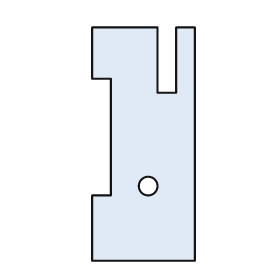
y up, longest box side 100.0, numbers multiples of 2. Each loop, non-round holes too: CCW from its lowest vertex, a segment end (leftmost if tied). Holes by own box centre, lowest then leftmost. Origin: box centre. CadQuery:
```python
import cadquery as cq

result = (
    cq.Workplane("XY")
    .moveTo(-22.0, -50.0)
    .lineTo(22.0, -50.0)
    .lineTo(22.0, 50.0)
    .lineTo(14.0, 50.0)
    .lineTo(14.0, 22.0)
    .lineTo(6.0, 22.0)
    .lineTo(6.0, 50.0)
    .lineTo(-22.0, 50.0)
    .lineTo(-22.0, 28.0)
    .lineTo(-14.0, 28.0)
    .lineTo(-14.0, -22.0)
    .lineTo(-22.0, -22.0)
    .close()
    .moveTo(2.0, -18.0)
    .circle(4.0)
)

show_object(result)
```